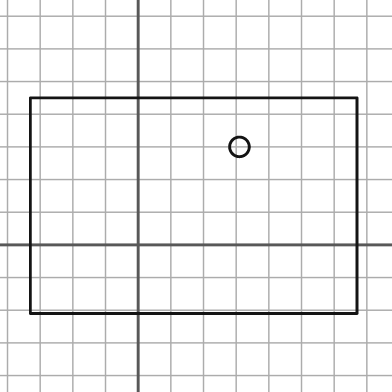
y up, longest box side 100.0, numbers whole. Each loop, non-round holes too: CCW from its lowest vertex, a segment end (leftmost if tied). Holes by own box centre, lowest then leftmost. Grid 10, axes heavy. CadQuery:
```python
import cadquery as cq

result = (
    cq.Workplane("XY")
    .moveTo(-33.0, -21.0)
    .lineTo(67.0, -21.0)
    .lineTo(67.0, 45.0)
    .lineTo(-33.0, 45.0)
    .close()
    .moveTo(31.0, 30.0)
    .circle(3.0)
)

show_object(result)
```